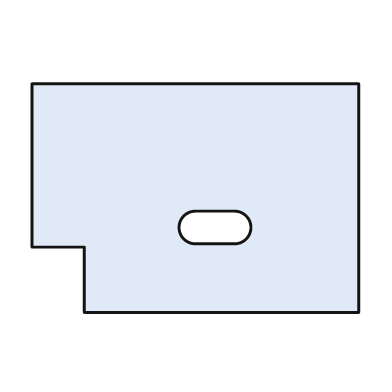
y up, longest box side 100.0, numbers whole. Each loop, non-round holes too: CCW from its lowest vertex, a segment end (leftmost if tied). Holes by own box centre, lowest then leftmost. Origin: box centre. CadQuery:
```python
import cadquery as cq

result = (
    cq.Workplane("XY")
    .moveTo(-34.0, -35.0)
    .lineTo(50.0, -35.0)
    .lineTo(50.0, 35.0)
    .lineTo(-50.0, 35.0)
    .lineTo(-50.0, -15.0)
    .lineTo(-34.0, -15.0)
    .close()
    .moveTo(0.0, -14.0)
    .lineTo(12.0, -14.0)
    .threePointArc((17.0, -9.0), (12.0, -4.0))
    .lineTo(0.0, -4.0)
    .threePointArc((-5.0, -9.0), (0.0, -14.0))
    .close()
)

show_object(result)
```